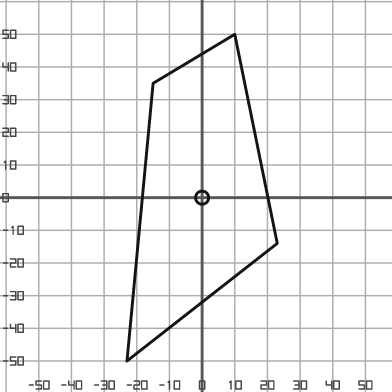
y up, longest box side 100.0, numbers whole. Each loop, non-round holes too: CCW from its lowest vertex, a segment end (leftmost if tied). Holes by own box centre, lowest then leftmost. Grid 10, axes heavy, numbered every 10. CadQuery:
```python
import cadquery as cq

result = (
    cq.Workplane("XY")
    .moveTo(-23.0, -50.0)
    .lineTo(23.0, -14.0)
    .lineTo(10.0, 50.0)
    .lineTo(-15.0, 35.0)
    .close()
    .moveTo(0.0, 0.0)
    .circle(2.0)
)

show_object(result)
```